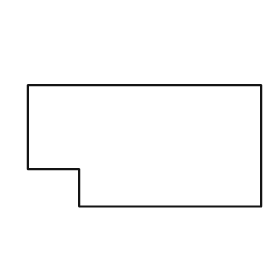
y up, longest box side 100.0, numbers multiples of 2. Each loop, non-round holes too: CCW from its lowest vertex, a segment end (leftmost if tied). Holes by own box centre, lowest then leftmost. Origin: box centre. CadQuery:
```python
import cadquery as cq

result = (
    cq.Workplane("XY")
    .moveTo(-28.0, -26.0)
    .lineTo(50.0, -26.0)
    .lineTo(50.0, 26.0)
    .lineTo(-50.0, 26.0)
    .lineTo(-50.0, -10.0)
    .lineTo(-28.0, -10.0)
    .close()
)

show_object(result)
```